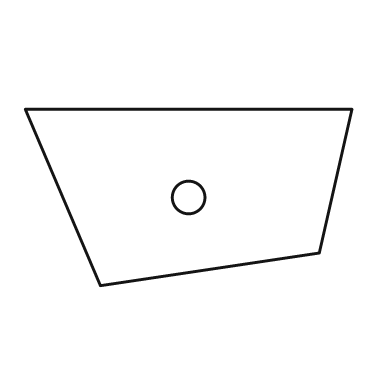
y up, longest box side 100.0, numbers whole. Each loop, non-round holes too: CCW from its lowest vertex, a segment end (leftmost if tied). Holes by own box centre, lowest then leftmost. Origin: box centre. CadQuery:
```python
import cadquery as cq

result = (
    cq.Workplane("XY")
    .moveTo(-27.0, -27.0)
    .lineTo(40.0, -17.0)
    .lineTo(50.0, 27.0)
    .lineTo(-50.0, 27.0)
    .close()
    .moveTo(0.0, 0.0)
    .circle(5.0)
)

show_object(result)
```